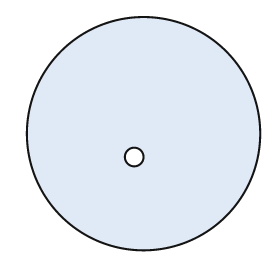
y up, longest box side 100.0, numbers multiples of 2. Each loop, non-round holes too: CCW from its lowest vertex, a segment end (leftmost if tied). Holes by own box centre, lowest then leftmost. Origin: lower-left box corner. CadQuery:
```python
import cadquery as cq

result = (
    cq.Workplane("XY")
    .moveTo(50.0, 50.0)
    .circle(50.0)
    .moveTo(46.0, 40.0)
    .circle(4.0)
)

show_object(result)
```